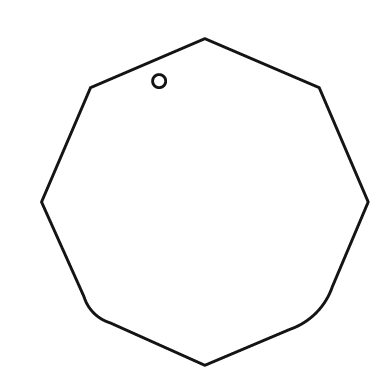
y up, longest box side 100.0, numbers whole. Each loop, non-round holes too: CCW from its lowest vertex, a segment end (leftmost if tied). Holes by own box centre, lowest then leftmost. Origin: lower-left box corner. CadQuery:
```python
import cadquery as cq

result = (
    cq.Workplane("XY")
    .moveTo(50.0, 0.0)
    .lineTo(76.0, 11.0)
    .threePointArc((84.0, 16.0), (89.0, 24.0))
    .lineTo(100.0, 50.0)
    .lineTo(85.0, 85.0)
    .lineTo(50.0, 100.0)
    .lineTo(15.0, 85.0)
    .lineTo(0.0, 50.0)
    .lineTo(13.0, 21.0)
    .threePointArc((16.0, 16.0), (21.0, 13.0))
    .close()
    .moveTo(36.0, 87.0)
    .circle(2.0)
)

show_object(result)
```